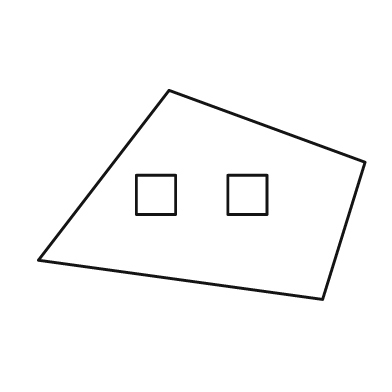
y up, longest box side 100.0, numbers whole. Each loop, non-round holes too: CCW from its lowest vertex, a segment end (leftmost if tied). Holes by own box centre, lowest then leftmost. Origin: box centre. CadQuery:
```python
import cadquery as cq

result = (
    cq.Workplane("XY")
    .moveTo(37.0, -32.0)
    .lineTo(50.0, 10.0)
    .lineTo(-10.0, 32.0)
    .lineTo(-50.0, -20.0)
    .close()
    .moveTo(-20.0, -6.0)
    .lineTo(-8.0, -6.0)
    .lineTo(-8.0, 6.0)
    .lineTo(-20.0, 6.0)
    .close()
    .moveTo(8.0, -6.0)
    .lineTo(20.0, -6.0)
    .lineTo(20.0, 6.0)
    .lineTo(8.0, 6.0)
    .close()
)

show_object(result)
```